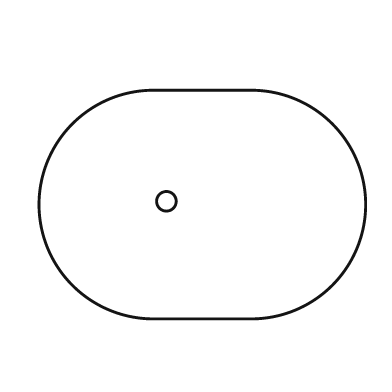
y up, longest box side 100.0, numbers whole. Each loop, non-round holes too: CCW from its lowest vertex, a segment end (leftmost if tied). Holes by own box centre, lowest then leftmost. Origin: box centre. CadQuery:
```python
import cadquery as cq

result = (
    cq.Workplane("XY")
    .moveTo(-15.0, -35.0)
    .lineTo(15.0, -35.0)
    .threePointArc((50.0, 0.0), (15.0, 35.0))
    .lineTo(-15.0, 35.0)
    .threePointArc((-50.0, 0.0), (-15.0, -35.0))
    .close()
    .moveTo(-11.0, 1.0)
    .circle(3.0)
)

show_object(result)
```